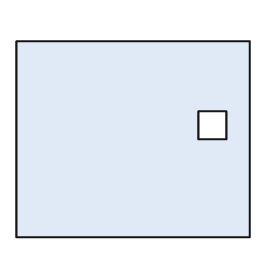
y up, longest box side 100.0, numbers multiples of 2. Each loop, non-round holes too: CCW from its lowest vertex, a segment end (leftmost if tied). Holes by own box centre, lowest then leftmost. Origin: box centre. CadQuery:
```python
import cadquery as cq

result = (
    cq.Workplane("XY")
    .moveTo(-50.0, -42.0)
    .lineTo(50.0, -42.0)
    .lineTo(50.0, 42.0)
    .lineTo(-50.0, 42.0)
    .close()
    .moveTo(28.0, 0.0)
    .lineTo(40.0, 0.0)
    .lineTo(40.0, 12.0)
    .lineTo(28.0, 12.0)
    .close()
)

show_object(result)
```